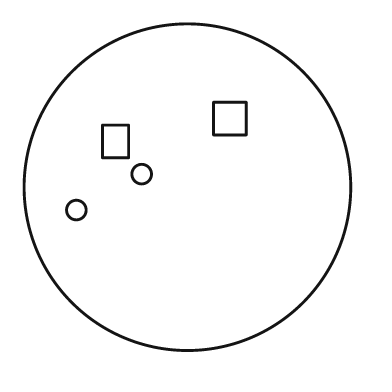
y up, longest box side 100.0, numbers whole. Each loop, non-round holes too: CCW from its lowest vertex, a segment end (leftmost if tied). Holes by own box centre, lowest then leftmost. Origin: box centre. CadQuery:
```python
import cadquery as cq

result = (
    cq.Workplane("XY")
    .moveTo(0.0, 0.0)
    .circle(50.0)
    .moveTo(-34.0, -7.0)
    .circle(3.0)
    .moveTo(-14.0, 4.0)
    .circle(3.0)
    .moveTo(-26.0, 9.0)
    .lineTo(-18.0, 9.0)
    .lineTo(-18.0, 19.0)
    .lineTo(-26.0, 19.0)
    .close()
    .moveTo(8.0, 16.0)
    .lineTo(18.0, 16.0)
    .lineTo(18.0, 26.0)
    .lineTo(8.0, 26.0)
    .close()
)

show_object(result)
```